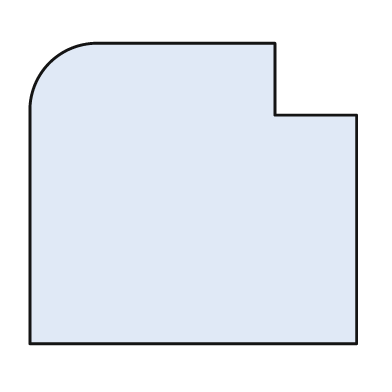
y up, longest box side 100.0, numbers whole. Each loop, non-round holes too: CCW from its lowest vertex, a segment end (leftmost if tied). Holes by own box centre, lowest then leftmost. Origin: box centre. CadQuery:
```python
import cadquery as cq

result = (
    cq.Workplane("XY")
    .moveTo(-50.0, -46.0)
    .lineTo(50.0, -46.0)
    .lineTo(50.0, 24.0)
    .lineTo(25.0, 24.0)
    .lineTo(25.0, 46.0)
    .lineTo(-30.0, 46.0)
    .threePointArc((-44.0, 40.0), (-50.0, 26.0))
    .close()
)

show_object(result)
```